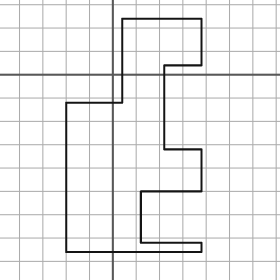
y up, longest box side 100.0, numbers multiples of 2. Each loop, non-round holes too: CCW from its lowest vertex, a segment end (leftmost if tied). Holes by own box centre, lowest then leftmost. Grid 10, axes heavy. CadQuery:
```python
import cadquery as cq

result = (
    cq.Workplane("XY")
    .moveTo(-20.0, -76.0)
    .lineTo(38.0, -76.0)
    .lineTo(38.0, -72.0)
    .lineTo(12.0, -72.0)
    .lineTo(12.0, -50.0)
    .lineTo(38.0, -50.0)
    .lineTo(38.0, -32.0)
    .lineTo(22.0, -32.0)
    .lineTo(22.0, 4.0)
    .lineTo(38.0, 4.0)
    .lineTo(38.0, 24.0)
    .lineTo(4.0, 24.0)
    .lineTo(4.0, -12.0)
    .lineTo(-20.0, -12.0)
    .close()
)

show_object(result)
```